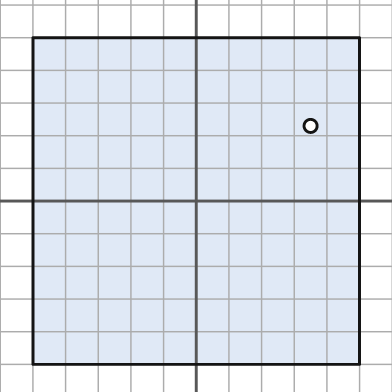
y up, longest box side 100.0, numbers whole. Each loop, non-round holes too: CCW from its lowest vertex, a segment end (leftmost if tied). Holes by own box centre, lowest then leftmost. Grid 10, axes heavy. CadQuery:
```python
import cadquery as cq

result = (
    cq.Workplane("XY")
    .moveTo(-50.0, -50.0)
    .lineTo(50.0, -50.0)
    .lineTo(50.0, 50.0)
    .lineTo(-50.0, 50.0)
    .close()
    .moveTo(35.0, 23.0)
    .circle(2.0)
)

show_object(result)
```